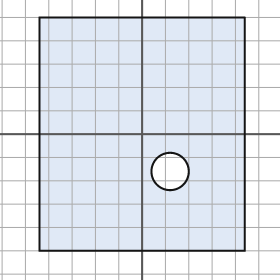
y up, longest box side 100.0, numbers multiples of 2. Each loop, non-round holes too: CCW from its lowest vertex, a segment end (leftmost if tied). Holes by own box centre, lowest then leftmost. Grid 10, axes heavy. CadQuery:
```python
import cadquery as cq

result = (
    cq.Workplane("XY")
    .moveTo(-44.0, -50.0)
    .lineTo(44.0, -50.0)
    .lineTo(44.0, 50.0)
    .lineTo(-44.0, 50.0)
    .close()
    .moveTo(12.0, -16.0)
    .circle(8.0)
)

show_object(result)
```